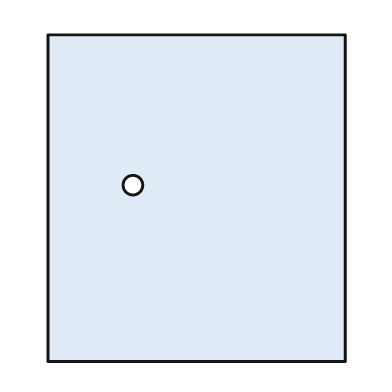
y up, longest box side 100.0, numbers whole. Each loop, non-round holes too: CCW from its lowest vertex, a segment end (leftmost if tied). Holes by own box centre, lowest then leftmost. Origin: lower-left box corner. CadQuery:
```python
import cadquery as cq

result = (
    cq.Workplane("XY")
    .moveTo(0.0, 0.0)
    .lineTo(91.0, 0.0)
    .lineTo(91.0, 100.0)
    .lineTo(0.0, 100.0)
    .close()
    .moveTo(26.0, 54.0)
    .circle(3.0)
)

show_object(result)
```